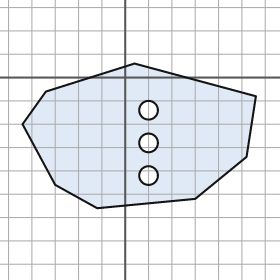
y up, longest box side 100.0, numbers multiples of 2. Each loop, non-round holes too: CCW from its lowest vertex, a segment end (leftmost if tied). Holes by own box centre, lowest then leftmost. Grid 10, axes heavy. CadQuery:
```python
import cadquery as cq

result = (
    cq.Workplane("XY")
    .moveTo(-12.0, -56.0)
    .lineTo(30.0, -52.0)
    .lineTo(52.0, -34.0)
    .lineTo(56.0, -8.0)
    .lineTo(4.0, 6.0)
    .lineTo(-34.0, -6.0)
    .lineTo(-44.0, -20.0)
    .lineTo(-30.0, -46.0)
    .close()
    .moveTo(10.0, -42.0)
    .circle(4.0)
    .moveTo(10.0, -28.0)
    .circle(4.0)
    .moveTo(10.0, -14.0)
    .circle(4.0)
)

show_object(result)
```